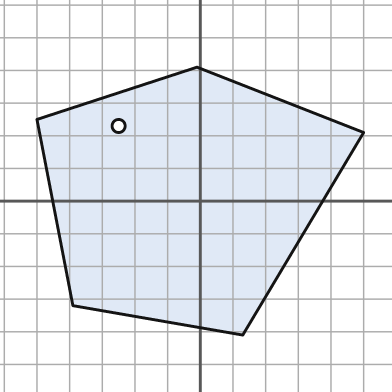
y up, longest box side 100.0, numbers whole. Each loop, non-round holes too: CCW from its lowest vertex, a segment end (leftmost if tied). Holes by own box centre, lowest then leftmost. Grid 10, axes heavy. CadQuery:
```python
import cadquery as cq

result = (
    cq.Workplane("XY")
    .moveTo(13.0, -41.0)
    .lineTo(50.0, 21.0)
    .lineTo(-1.0, 41.0)
    .lineTo(-50.0, 25.0)
    .lineTo(-39.0, -32.0)
    .close()
    .moveTo(-25.0, 23.0)
    .circle(2.0)
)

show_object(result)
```